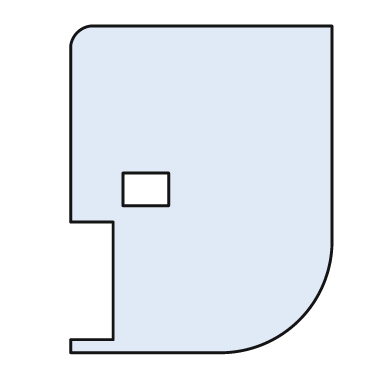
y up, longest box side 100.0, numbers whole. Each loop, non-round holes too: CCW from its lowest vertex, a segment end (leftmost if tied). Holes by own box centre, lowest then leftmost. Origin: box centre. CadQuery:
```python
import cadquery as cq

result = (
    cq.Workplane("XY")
    .moveTo(-40.0, -50.0)
    .lineTo(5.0, -50.0)
    .threePointArc((30.0, -40.0), (40.0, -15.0))
    .lineTo(40.0, 50.0)
    .lineTo(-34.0, 50.0)
    .threePointArc((-38.0, 48.0), (-40.0, 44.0))
    .lineTo(-40.0, -10.0)
    .lineTo(-27.0, -10.0)
    .lineTo(-27.0, -46.0)
    .lineTo(-40.0, -46.0)
    .close()
    .moveTo(-24.0, -5.0)
    .lineTo(-10.0, -5.0)
    .lineTo(-10.0, 5.0)
    .lineTo(-24.0, 5.0)
    .close()
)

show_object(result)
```